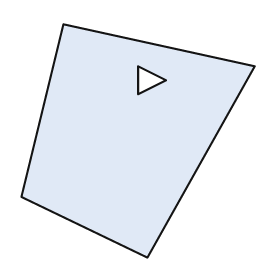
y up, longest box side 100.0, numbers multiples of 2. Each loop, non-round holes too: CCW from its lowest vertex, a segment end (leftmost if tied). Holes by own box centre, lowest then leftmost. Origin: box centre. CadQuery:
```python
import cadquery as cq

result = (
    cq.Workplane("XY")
    .moveTo(4.0, -50.0)
    .lineTo(50.0, 32.0)
    .lineTo(-32.0, 50.0)
    .lineTo(-50.0, -24.0)
    .close()
    .moveTo(0.0, 20.0)
    .lineTo(12.0, 26.0)
    .lineTo(0.0, 32.0)
    .close()
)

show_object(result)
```